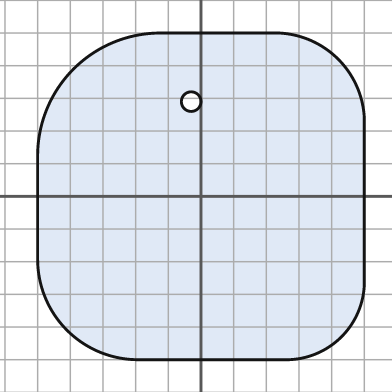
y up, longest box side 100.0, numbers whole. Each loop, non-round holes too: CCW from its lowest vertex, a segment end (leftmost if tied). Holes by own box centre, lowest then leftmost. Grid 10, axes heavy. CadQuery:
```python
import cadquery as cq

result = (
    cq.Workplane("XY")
    .moveTo(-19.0, -50.0)
    .lineTo(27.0, -50.0)
    .threePointArc((43.0, -43.0), (50.0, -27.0))
    .lineTo(50.0, 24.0)
    .threePointArc((42.0, 42.0), (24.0, 50.0))
    .lineTo(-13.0, 50.0)
    .threePointArc((-39.0, 39.0), (-50.0, 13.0))
    .lineTo(-50.0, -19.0)
    .threePointArc((-41.0, -41.0), (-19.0, -50.0))
    .close()
    .moveTo(-3.0, 29.0)
    .circle(3.0)
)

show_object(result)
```